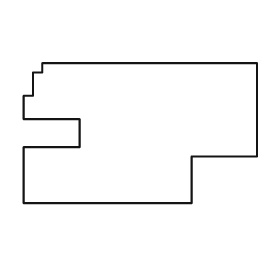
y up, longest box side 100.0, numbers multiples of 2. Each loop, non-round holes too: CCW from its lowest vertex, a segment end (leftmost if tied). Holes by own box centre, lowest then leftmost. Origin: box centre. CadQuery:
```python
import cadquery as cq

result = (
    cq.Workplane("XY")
    .moveTo(-50.0, -30.0)
    .lineTo(22.0, -30.0)
    .lineTo(22.0, -10.0)
    .lineTo(50.0, -10.0)
    .lineTo(50.0, 30.0)
    .lineTo(-42.0, 30.0)
    .lineTo(-42.0, 26.0)
    .lineTo(-46.0, 26.0)
    .lineTo(-46.0, 16.0)
    .lineTo(-50.0, 16.0)
    .lineTo(-50.0, 6.0)
    .lineTo(-26.0, 6.0)
    .lineTo(-26.0, -6.0)
    .lineTo(-50.0, -6.0)
    .close()
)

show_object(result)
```